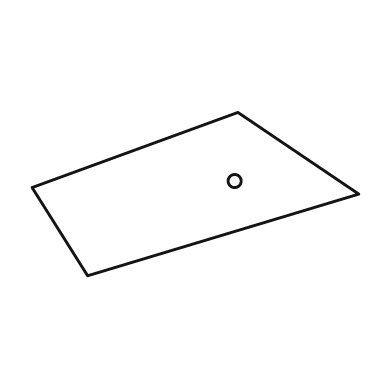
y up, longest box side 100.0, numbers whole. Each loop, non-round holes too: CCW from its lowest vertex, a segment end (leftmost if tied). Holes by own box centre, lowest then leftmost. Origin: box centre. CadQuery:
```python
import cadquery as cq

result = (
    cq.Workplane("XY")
    .moveTo(-33.0, -25.0)
    .lineTo(50.0, 0.0)
    .lineTo(13.0, 25.0)
    .lineTo(-50.0, 2.0)
    .close()
    .moveTo(12.0, 4.0)
    .circle(2.0)
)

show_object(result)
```